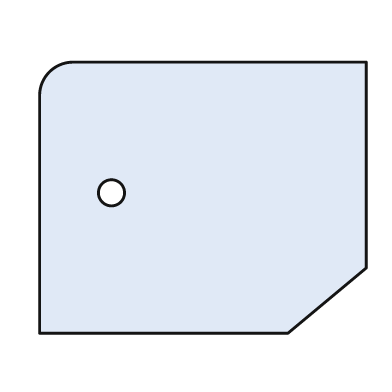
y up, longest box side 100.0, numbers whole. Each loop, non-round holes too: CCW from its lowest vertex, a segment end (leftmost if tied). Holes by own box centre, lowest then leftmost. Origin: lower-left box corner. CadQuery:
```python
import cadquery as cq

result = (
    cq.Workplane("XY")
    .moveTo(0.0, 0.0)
    .lineTo(76.0, 0.0)
    .lineTo(100.0, 20.0)
    .lineTo(100.0, 83.0)
    .lineTo(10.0, 83.0)
    .threePointArc((3.0, 80.0), (0.0, 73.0))
    .close()
    .moveTo(22.0, 43.0)
    .circle(4.0)
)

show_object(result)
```